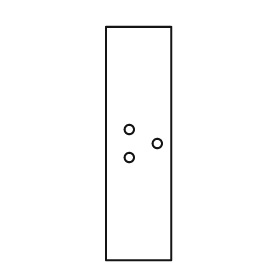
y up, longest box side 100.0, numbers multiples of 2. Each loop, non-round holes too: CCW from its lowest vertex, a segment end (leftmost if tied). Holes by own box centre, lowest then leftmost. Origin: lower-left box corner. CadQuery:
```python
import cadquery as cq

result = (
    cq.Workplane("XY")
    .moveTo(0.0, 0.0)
    .lineTo(28.0, 0.0)
    .lineTo(28.0, 100.0)
    .lineTo(0.0, 100.0)
    .close()
    .moveTo(10.0, 44.0)
    .circle(2.0)
    .moveTo(22.0, 50.0)
    .circle(2.0)
    .moveTo(10.0, 56.0)
    .circle(2.0)
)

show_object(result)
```